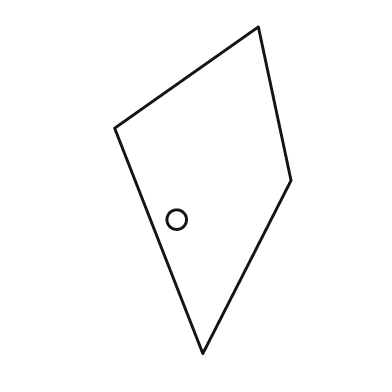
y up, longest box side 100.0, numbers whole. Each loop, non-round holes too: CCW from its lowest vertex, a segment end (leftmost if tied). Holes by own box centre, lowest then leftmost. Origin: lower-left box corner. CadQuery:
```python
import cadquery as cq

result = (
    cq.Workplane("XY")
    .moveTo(27.0, 0.0)
    .lineTo(54.0, 53.0)
    .lineTo(44.0, 100.0)
    .lineTo(0.0, 69.0)
    .close()
    .moveTo(19.0, 41.0)
    .circle(3.0)
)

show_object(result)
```